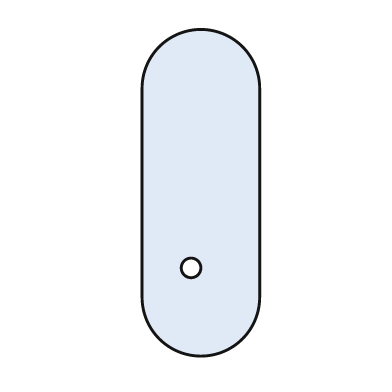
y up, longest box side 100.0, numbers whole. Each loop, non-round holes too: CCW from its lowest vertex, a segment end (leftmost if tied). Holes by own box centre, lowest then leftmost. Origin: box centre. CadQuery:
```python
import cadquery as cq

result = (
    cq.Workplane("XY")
    .moveTo(-18.0, -32.0)
    .threePointArc((0.0, -50.0), (18.0, -32.0))
    .lineTo(18.0, 32.0)
    .threePointArc((0.0, 50.0), (-18.0, 32.0))
    .close()
    .moveTo(-3.0, -23.0)
    .circle(3.0)
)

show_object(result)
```